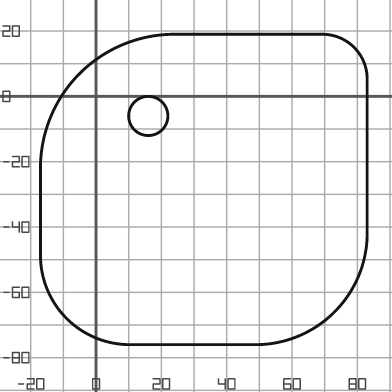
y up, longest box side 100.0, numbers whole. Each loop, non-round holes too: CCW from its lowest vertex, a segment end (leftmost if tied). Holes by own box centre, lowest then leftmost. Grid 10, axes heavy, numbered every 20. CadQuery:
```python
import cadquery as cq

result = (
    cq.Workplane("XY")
    .moveTo(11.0, -76.0)
    .lineTo(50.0, -76.0)
    .threePointArc((73.0, -66.0), (83.0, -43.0))
    .lineTo(83.0, 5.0)
    .threePointArc((79.0, 15.0), (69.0, 19.0))
    .lineTo(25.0, 19.0)
    .threePointArc((-5.0, 7.0), (-17.0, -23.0))
    .lineTo(-17.0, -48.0)
    .threePointArc((-9.0, -68.0), (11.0, -76.0))
    .close()
    .moveTo(16.0, -6.0)
    .circle(6.0)
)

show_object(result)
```